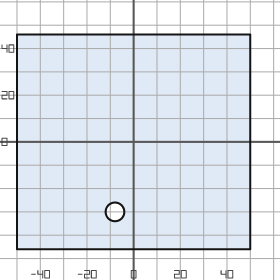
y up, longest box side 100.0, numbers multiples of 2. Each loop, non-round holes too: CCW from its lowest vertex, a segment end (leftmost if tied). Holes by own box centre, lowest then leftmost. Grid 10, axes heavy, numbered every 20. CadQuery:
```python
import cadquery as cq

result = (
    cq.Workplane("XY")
    .moveTo(-50.0, -46.0)
    .lineTo(50.0, -46.0)
    .lineTo(50.0, 46.0)
    .lineTo(-50.0, 46.0)
    .close()
    .moveTo(-8.0, -30.0)
    .circle(4.0)
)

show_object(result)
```